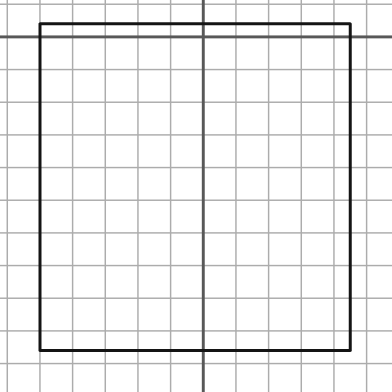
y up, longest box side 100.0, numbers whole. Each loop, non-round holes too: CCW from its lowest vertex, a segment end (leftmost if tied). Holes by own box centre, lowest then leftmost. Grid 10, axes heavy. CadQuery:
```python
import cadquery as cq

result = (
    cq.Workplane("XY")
    .moveTo(-50.0, -96.0)
    .lineTo(45.0, -96.0)
    .lineTo(45.0, 4.0)
    .lineTo(-50.0, 4.0)
    .close()
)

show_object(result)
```